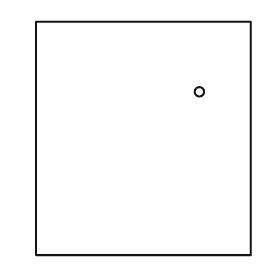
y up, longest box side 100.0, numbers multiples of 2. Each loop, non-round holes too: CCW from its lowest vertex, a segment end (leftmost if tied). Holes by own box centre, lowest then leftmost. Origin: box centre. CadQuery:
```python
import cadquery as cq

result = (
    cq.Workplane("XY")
    .moveTo(-46.0, -50.0)
    .lineTo(46.0, -50.0)
    .lineTo(46.0, 50.0)
    .lineTo(-46.0, 50.0)
    .close()
    .moveTo(24.0, 20.0)
    .circle(2.0)
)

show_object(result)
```